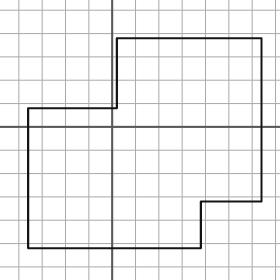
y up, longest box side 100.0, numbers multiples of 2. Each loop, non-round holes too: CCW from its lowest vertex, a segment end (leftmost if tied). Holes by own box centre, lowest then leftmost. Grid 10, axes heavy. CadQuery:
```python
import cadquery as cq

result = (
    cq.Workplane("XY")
    .moveTo(-36.0, -52.0)
    .lineTo(38.0, -52.0)
    .lineTo(38.0, -32.0)
    .lineTo(64.0, -32.0)
    .lineTo(64.0, 38.0)
    .lineTo(2.0, 38.0)
    .lineTo(2.0, 8.0)
    .lineTo(-36.0, 8.0)
    .close()
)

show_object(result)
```